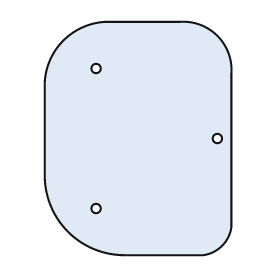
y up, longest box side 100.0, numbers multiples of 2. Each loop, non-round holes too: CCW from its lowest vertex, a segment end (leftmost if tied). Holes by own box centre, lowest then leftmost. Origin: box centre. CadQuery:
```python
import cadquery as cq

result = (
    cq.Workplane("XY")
    .moveTo(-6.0, -50.0)
    .lineTo(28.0, -50.0)
    .threePointArc((36.0, -46.0), (40.0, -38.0))
    .lineTo(40.0, 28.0)
    .threePointArc((34.0, 44.0), (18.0, 50.0))
    .lineTo(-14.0, 50.0)
    .threePointArc((-32.0, 42.0), (-40.0, 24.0))
    .lineTo(-40.0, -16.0)
    .threePointArc((-30.0, -40.0), (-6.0, -50.0))
    .close()
    .moveTo(-18.0, -30.0)
    .circle(2.0)
    .moveTo(34.0, 0.0)
    .circle(2.0)
    .moveTo(-18.0, 30.0)
    .circle(2.0)
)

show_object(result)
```